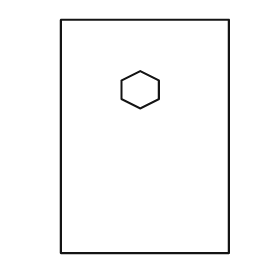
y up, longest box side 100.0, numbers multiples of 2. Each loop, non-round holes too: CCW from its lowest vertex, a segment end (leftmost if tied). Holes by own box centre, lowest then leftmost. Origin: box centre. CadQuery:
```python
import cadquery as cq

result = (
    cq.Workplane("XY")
    .moveTo(-36.0, -50.0)
    .lineTo(36.0, -50.0)
    .lineTo(36.0, 50.0)
    .lineTo(-36.0, 50.0)
    .close()
    .moveTo(-2.0, 12.0)
    .lineTo(6.0, 16.0)
    .lineTo(6.0, 24.0)
    .lineTo(-2.0, 28.0)
    .lineTo(-10.0, 24.0)
    .lineTo(-10.0, 16.0)
    .close()
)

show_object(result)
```